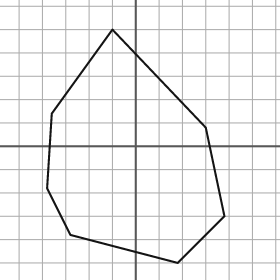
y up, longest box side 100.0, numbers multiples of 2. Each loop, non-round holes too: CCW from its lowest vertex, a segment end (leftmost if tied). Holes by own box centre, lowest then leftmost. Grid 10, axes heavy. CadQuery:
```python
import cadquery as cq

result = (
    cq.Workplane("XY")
    .moveTo(18.0, -50.0)
    .lineTo(38.0, -30.0)
    .lineTo(30.0, 8.0)
    .lineTo(-10.0, 50.0)
    .lineTo(-36.0, 14.0)
    .lineTo(-38.0, -18.0)
    .lineTo(-28.0, -38.0)
    .close()
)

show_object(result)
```